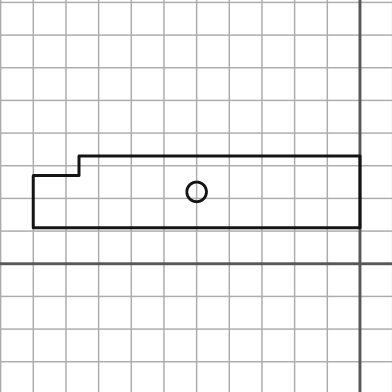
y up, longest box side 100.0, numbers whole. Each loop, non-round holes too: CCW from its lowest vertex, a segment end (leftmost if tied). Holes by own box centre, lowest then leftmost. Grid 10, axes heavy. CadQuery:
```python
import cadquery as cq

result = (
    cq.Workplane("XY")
    .moveTo(-100.0, 11.0)
    .lineTo(0.0, 11.0)
    .lineTo(0.0, 33.0)
    .lineTo(-86.0, 33.0)
    .lineTo(-86.0, 27.0)
    .lineTo(-100.0, 27.0)
    .close()
    .moveTo(-50.0, 22.0)
    .circle(3.0)
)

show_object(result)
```